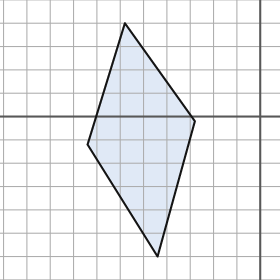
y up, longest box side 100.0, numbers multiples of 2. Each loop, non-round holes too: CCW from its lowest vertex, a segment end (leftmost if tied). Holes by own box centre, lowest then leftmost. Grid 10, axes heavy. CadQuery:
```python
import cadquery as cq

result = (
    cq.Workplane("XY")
    .moveTo(-44.0, -60.0)
    .lineTo(-28.0, -2.0)
    .lineTo(-58.0, 40.0)
    .lineTo(-74.0, -12.0)
    .close()
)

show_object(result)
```